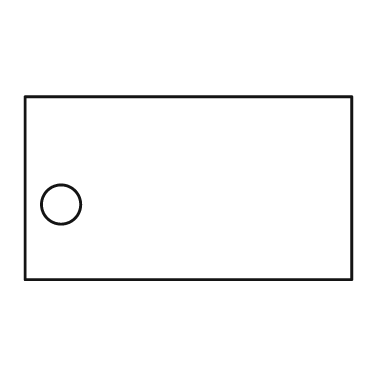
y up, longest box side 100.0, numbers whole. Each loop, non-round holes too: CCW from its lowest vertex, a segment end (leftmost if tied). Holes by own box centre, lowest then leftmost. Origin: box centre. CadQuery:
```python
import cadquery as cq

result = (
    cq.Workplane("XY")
    .moveTo(-50.0, -28.0)
    .lineTo(50.0, -28.0)
    .lineTo(50.0, 28.0)
    .lineTo(-50.0, 28.0)
    .close()
    .moveTo(-39.0, -5.0)
    .circle(6.0)
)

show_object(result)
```